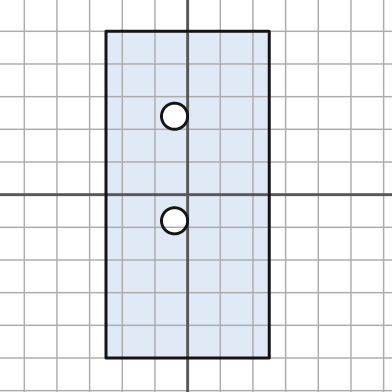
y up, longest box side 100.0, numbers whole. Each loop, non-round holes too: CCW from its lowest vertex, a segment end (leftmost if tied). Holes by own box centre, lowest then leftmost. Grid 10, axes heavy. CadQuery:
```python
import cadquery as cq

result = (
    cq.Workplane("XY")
    .moveTo(-25.0, -50.0)
    .lineTo(25.0, -50.0)
    .lineTo(25.0, 50.0)
    .lineTo(-25.0, 50.0)
    .close()
    .moveTo(-4.0, -8.0)
    .circle(4.0)
    .moveTo(-4.0, 24.0)
    .circle(4.0)
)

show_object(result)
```